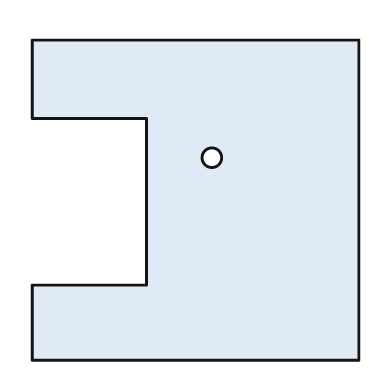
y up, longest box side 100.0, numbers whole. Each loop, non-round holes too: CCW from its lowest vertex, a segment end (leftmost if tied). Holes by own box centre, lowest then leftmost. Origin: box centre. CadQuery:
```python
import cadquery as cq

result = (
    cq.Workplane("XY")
    .moveTo(-50.0, -49.0)
    .lineTo(50.0, -49.0)
    .lineTo(50.0, 49.0)
    .lineTo(-50.0, 49.0)
    .lineTo(-50.0, 25.0)
    .lineTo(-15.0, 25.0)
    .lineTo(-15.0, -26.0)
    .lineTo(-50.0, -26.0)
    .close()
    .moveTo(5.0, 13.0)
    .circle(3.0)
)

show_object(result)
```